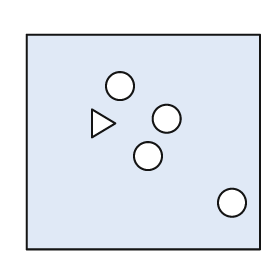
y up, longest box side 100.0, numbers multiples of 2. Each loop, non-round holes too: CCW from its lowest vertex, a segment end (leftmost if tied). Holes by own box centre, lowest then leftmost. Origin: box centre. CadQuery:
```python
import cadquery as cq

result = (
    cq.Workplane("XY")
    .moveTo(-50.0, -46.0)
    .lineTo(50.0, -46.0)
    .lineTo(50.0, 46.0)
    .lineTo(-50.0, 46.0)
    .close()
    .moveTo(38.0, -26.0)
    .circle(6.0)
    .moveTo(2.0, -6.0)
    .circle(6.0)
    .moveTo(-22.0, 2.0)
    .lineTo(-12.0, 8.0)
    .lineTo(-22.0, 14.0)
    .close()
    .moveTo(10.0, 10.0)
    .circle(6.0)
    .moveTo(-10.0, 24.0)
    .circle(6.0)
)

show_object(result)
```